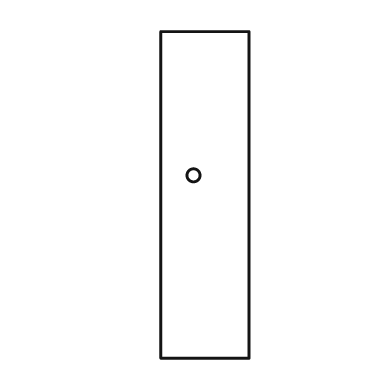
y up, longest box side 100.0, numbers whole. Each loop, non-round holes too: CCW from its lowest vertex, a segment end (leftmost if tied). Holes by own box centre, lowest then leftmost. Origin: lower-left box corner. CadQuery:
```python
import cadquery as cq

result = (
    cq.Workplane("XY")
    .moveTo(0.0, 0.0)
    .lineTo(27.0, 0.0)
    .lineTo(27.0, 100.0)
    .lineTo(0.0, 100.0)
    .close()
    .moveTo(10.0, 56.0)
    .circle(2.0)
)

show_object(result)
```